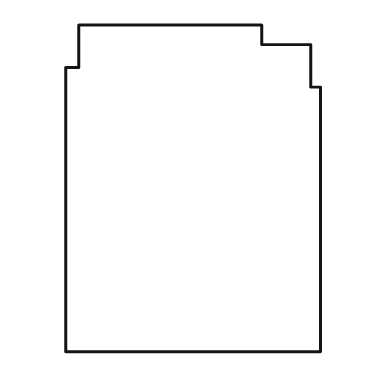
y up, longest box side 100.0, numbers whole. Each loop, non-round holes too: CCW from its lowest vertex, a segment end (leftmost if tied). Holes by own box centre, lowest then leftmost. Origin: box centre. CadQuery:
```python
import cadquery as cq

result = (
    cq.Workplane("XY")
    .moveTo(-39.0, -50.0)
    .lineTo(39.0, -50.0)
    .lineTo(39.0, 31.0)
    .lineTo(36.0, 31.0)
    .lineTo(36.0, 44.0)
    .lineTo(21.0, 44.0)
    .lineTo(21.0, 50.0)
    .lineTo(-35.0, 50.0)
    .lineTo(-35.0, 37.0)
    .lineTo(-39.0, 37.0)
    .close()
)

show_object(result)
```